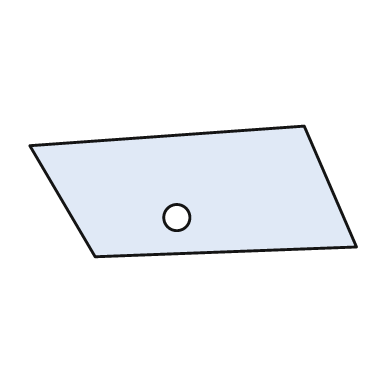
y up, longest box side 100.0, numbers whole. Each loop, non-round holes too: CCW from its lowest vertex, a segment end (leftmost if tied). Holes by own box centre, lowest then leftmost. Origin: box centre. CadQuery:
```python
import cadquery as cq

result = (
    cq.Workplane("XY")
    .moveTo(-30.0, -20.0)
    .lineTo(50.0, -17.0)
    .lineTo(34.0, 20.0)
    .lineTo(-50.0, 14.0)
    .close()
    .moveTo(-5.0, -8.0)
    .circle(4.0)
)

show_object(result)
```